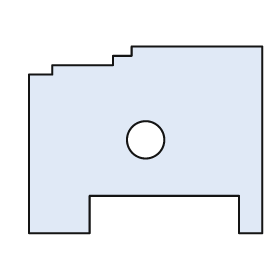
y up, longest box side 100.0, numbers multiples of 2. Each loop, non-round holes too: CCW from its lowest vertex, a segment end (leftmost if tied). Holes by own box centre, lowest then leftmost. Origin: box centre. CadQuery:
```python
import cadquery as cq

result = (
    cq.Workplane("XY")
    .moveTo(-50.0, -40.0)
    .lineTo(-24.0, -40.0)
    .lineTo(-24.0, -24.0)
    .lineTo(40.0, -24.0)
    .lineTo(40.0, -40.0)
    .lineTo(50.0, -40.0)
    .lineTo(50.0, 40.0)
    .lineTo(-6.0, 40.0)
    .lineTo(-6.0, 36.0)
    .lineTo(-14.0, 36.0)
    .lineTo(-14.0, 32.0)
    .lineTo(-40.0, 32.0)
    .lineTo(-40.0, 28.0)
    .lineTo(-50.0, 28.0)
    .close()
    .moveTo(0.0, 0.0)
    .circle(8.0)
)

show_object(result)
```